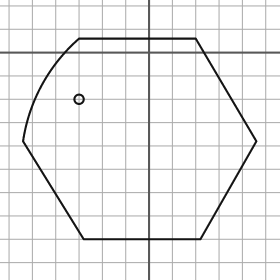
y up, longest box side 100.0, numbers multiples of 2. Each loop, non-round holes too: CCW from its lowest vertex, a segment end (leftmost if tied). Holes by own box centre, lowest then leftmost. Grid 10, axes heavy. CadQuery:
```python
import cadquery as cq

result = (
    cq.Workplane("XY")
    .moveTo(-28.0, -80.0)
    .lineTo(22.0, -80.0)
    .lineTo(46.0, -38.0)
    .lineTo(20.0, 6.0)
    .lineTo(-30.0, 6.0)
    .threePointArc((-46.0, -14.0), (-54.0, -38.0))
    .close()
    .moveTo(-30.0, -20.0)
    .circle(2.0)
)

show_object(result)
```